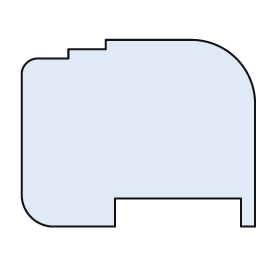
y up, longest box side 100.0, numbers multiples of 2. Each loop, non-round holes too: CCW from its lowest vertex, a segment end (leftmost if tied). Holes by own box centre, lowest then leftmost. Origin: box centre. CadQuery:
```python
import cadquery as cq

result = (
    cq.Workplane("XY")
    .moveTo(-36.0, -40.0)
    .lineTo(-10.0, -40.0)
    .lineTo(-10.0, -28.0)
    .lineTo(44.0, -28.0)
    .lineTo(44.0, -40.0)
    .lineTo(50.0, -40.0)
    .lineTo(50.0, 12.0)
    .threePointArc((42.0, 32.0), (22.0, 40.0))
    .lineTo(-14.0, 40.0)
    .lineTo(-14.0, 36.0)
    .lineTo(-30.0, 36.0)
    .lineTo(-30.0, 32.0)
    .lineTo(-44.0, 32.0)
    .threePointArc((-48.0, 30.0), (-50.0, 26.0))
    .lineTo(-50.0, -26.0)
    .threePointArc((-46.0, -36.0), (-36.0, -40.0))
    .close()
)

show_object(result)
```